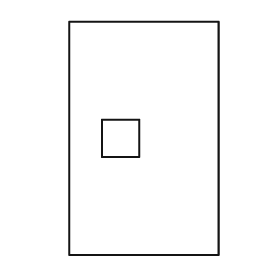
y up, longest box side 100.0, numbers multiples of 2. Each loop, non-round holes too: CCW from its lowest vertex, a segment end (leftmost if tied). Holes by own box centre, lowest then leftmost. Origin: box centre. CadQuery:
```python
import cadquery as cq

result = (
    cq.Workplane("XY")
    .moveTo(-32.0, -50.0)
    .lineTo(32.0, -50.0)
    .lineTo(32.0, 50.0)
    .lineTo(-32.0, 50.0)
    .close()
    .moveTo(-18.0, -8.0)
    .lineTo(-2.0, -8.0)
    .lineTo(-2.0, 8.0)
    .lineTo(-18.0, 8.0)
    .close()
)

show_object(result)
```